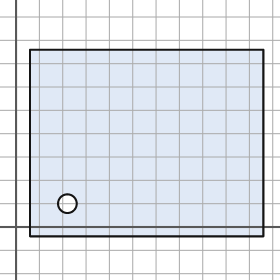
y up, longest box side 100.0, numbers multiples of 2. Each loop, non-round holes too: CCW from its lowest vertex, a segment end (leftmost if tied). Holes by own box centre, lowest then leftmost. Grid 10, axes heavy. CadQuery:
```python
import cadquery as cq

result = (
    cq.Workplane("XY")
    .moveTo(6.0, -4.0)
    .lineTo(106.0, -4.0)
    .lineTo(106.0, 76.0)
    .lineTo(6.0, 76.0)
    .close()
    .moveTo(22.0, 10.0)
    .circle(4.0)
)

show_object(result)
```